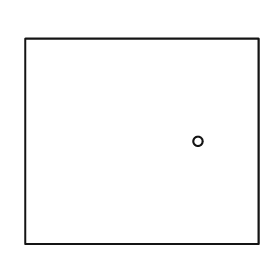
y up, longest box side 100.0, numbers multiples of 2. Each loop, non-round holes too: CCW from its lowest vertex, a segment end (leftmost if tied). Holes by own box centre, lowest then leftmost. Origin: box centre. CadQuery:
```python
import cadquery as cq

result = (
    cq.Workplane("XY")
    .moveTo(-50.0, -44.0)
    .lineTo(50.0, -44.0)
    .lineTo(50.0, 44.0)
    .lineTo(-50.0, 44.0)
    .close()
    .moveTo(24.0, 0.0)
    .circle(2.0)
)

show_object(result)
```